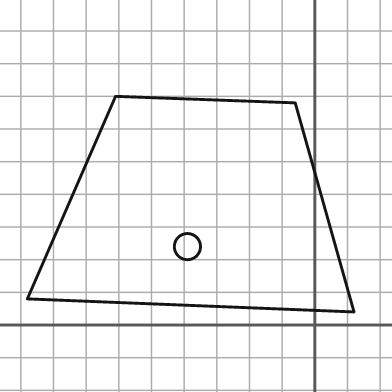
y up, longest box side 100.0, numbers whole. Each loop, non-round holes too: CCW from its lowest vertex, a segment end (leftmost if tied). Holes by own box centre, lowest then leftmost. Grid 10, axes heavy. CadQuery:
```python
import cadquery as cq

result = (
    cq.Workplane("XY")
    .moveTo(12.0, 4.0)
    .lineTo(-6.0, 68.0)
    .lineTo(-61.0, 70.0)
    .lineTo(-88.0, 8.0)
    .close()
    .moveTo(-39.0, 24.0)
    .circle(4.0)
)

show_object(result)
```